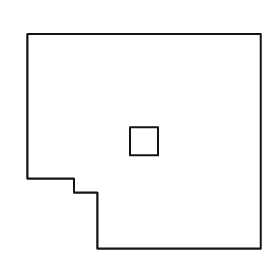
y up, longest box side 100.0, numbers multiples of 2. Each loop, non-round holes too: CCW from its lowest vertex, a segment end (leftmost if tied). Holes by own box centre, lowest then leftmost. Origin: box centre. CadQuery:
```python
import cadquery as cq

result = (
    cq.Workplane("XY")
    .moveTo(-20.0, -46.0)
    .lineTo(50.0, -46.0)
    .lineTo(50.0, 46.0)
    .lineTo(-50.0, 46.0)
    .lineTo(-50.0, -16.0)
    .lineTo(-30.0, -16.0)
    .lineTo(-30.0, -22.0)
    .lineTo(-20.0, -22.0)
    .close()
    .moveTo(-6.0, -6.0)
    .lineTo(6.0, -6.0)
    .lineTo(6.0, 6.0)
    .lineTo(-6.0, 6.0)
    .close()
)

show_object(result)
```